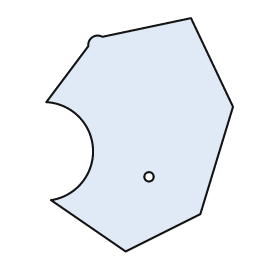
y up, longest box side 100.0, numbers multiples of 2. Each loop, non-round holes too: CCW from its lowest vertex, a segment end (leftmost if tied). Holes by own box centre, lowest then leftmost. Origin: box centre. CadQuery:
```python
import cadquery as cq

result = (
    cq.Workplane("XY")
    .moveTo(-6.0, -50.0)
    .lineTo(26.0, -34.0)
    .lineTo(40.0, 12.0)
    .lineTo(22.0, 50.0)
    .lineTo(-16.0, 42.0)
    .threePointArc((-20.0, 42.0), (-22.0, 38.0))
    .lineTo(-40.0, 14.0)
    .threePointArc((-20.0, -6.0), (-38.0, -28.0))
    .close()
    .moveTo(4.0, -18.0)
    .circle(2.0)
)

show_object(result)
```